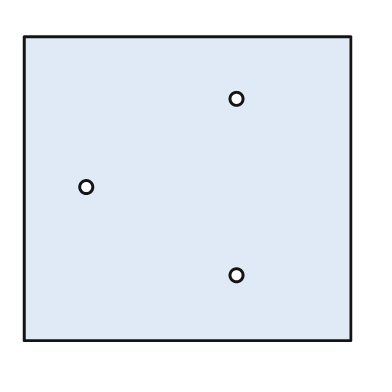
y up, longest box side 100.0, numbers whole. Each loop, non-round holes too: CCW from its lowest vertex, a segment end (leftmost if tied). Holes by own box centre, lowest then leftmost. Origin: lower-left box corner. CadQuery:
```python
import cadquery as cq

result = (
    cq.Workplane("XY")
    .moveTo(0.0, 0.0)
    .lineTo(100.0, 0.0)
    .lineTo(100.0, 93.0)
    .lineTo(0.0, 93.0)
    .close()
    .moveTo(65.0, 20.0)
    .circle(2.0)
    .moveTo(19.0, 47.0)
    .circle(2.0)
    .moveTo(65.0, 74.0)
    .circle(2.0)
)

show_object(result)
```